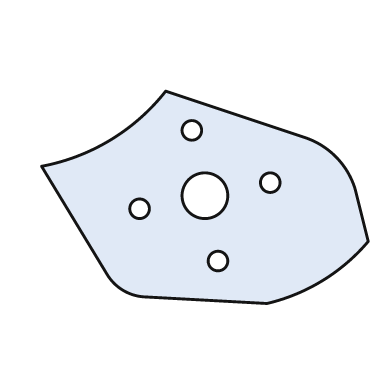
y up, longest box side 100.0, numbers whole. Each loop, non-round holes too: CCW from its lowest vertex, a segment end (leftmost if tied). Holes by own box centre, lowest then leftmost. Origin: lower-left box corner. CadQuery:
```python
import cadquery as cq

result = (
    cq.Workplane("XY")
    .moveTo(69.0, 0.0)
    .threePointArc((86.0, 7.0), (100.0, 19.0))
    .lineTo(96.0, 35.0)
    .threePointArc((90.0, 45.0), (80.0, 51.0))
    .lineTo(38.0, 65.0)
    .threePointArc((21.0, 50.0), (0.0, 42.0))
    .lineTo(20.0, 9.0)
    .threePointArc((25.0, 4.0), (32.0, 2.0))
    .close()
    .moveTo(54.0, 13.0)
    .circle(3.0)
    .moveTo(30.0, 29.0)
    .circle(3.0)
    .moveTo(50.0, 33.0)
    .circle(7.0)
    .moveTo(70.0, 37.0)
    .circle(3.0)
    .moveTo(46.0, 53.0)
    .circle(3.0)
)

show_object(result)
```